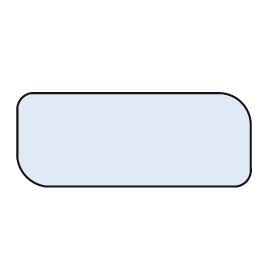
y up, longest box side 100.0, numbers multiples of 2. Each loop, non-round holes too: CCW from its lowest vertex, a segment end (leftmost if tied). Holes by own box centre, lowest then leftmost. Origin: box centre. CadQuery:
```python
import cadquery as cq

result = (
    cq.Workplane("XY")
    .moveTo(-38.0, -20.0)
    .lineTo(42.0, -20.0)
    .threePointArc((48.0, -18.0), (50.0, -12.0))
    .lineTo(50.0, 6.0)
    .threePointArc((46.0, 16.0), (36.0, 20.0))
    .lineTo(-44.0, 20.0)
    .threePointArc((-48.0, 18.0), (-50.0, 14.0))
    .lineTo(-50.0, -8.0)
    .threePointArc((-46.0, -16.0), (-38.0, -20.0))
    .close()
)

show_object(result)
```